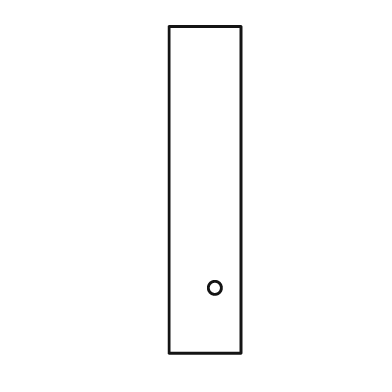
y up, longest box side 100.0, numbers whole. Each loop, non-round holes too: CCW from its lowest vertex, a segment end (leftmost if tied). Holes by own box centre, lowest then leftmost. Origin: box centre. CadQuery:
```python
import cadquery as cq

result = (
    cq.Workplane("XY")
    .moveTo(-11.0, -50.0)
    .lineTo(11.0, -50.0)
    .lineTo(11.0, 50.0)
    .lineTo(-11.0, 50.0)
    .close()
    .moveTo(3.0, -30.0)
    .circle(2.0)
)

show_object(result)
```